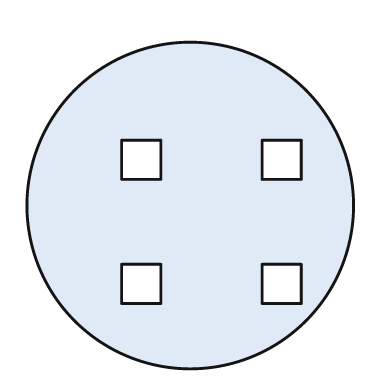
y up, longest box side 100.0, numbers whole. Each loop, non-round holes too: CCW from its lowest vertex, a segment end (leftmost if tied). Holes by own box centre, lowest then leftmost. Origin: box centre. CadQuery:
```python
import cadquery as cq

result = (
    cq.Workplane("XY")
    .moveTo(0.0, 0.0)
    .circle(50.0)
    .moveTo(-21.0, -30.0)
    .lineTo(-9.0, -30.0)
    .lineTo(-9.0, -18.0)
    .lineTo(-21.0, -18.0)
    .close()
    .moveTo(22.0, -30.0)
    .lineTo(34.0, -30.0)
    .lineTo(34.0, -18.0)
    .lineTo(22.0, -18.0)
    .close()
    .moveTo(-21.0, 8.0)
    .lineTo(-9.0, 8.0)
    .lineTo(-9.0, 20.0)
    .lineTo(-21.0, 20.0)
    .close()
    .moveTo(22.0, 8.0)
    .lineTo(34.0, 8.0)
    .lineTo(34.0, 20.0)
    .lineTo(22.0, 20.0)
    .close()
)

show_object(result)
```